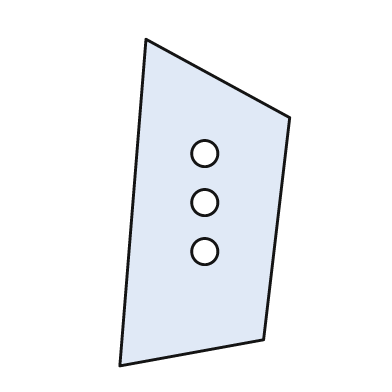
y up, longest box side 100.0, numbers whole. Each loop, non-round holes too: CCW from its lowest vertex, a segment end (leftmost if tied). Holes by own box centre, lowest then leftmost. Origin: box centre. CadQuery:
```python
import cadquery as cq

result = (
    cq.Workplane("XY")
    .moveTo(-26.0, -50.0)
    .lineTo(18.0, -42.0)
    .lineTo(26.0, 26.0)
    .lineTo(-18.0, 50.0)
    .close()
    .moveTo(0.0, -15.0)
    .circle(4.0)
    .moveTo(0.0, 0.0)
    .circle(4.0)
    .moveTo(0.0, 15.0)
    .circle(4.0)
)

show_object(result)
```